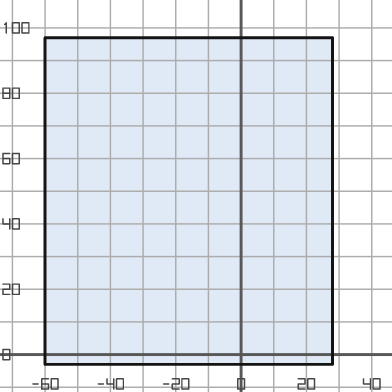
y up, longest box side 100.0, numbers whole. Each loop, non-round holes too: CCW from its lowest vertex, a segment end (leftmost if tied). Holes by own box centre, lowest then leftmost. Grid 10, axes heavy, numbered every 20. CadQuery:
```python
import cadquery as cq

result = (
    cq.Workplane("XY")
    .moveTo(-60.0, -3.0)
    .lineTo(28.0, -3.0)
    .lineTo(28.0, 97.0)
    .lineTo(-60.0, 97.0)
    .close()
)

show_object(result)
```